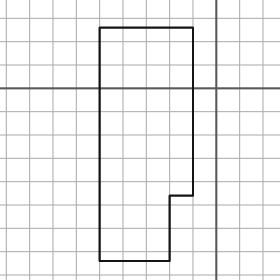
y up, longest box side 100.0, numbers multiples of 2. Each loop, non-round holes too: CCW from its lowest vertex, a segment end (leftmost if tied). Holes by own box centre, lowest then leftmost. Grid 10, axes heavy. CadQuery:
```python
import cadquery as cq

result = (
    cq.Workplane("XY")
    .moveTo(-50.0, -74.0)
    .lineTo(-20.0, -74.0)
    .lineTo(-20.0, -46.0)
    .lineTo(-10.0, -46.0)
    .lineTo(-10.0, 26.0)
    .lineTo(-50.0, 26.0)
    .close()
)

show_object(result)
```